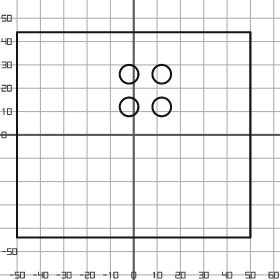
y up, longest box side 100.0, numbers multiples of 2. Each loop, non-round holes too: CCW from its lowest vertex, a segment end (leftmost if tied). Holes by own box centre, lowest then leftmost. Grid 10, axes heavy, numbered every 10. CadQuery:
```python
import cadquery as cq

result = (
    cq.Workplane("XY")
    .moveTo(-50.0, -44.0)
    .lineTo(50.0, -44.0)
    .lineTo(50.0, 44.0)
    .lineTo(-50.0, 44.0)
    .close()
    .moveTo(-2.0, 12.0)
    .circle(4.0)
    .moveTo(12.0, 12.0)
    .circle(4.0)
    .moveTo(-2.0, 26.0)
    .circle(4.0)
    .moveTo(12.0, 26.0)
    .circle(4.0)
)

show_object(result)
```